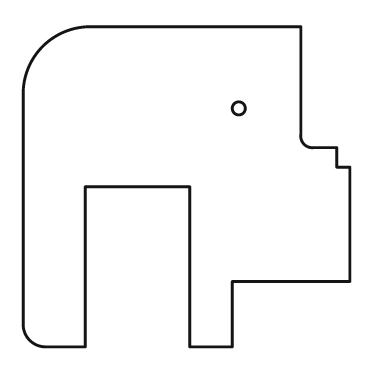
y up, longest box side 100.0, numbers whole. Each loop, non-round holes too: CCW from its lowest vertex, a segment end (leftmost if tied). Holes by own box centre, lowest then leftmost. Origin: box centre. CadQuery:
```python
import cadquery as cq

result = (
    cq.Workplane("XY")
    .moveTo(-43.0, -49.0)
    .lineTo(-31.0, -49.0)
    .lineTo(-31.0, 0.0)
    .lineTo(1.0, 0.0)
    .lineTo(1.0, -49.0)
    .lineTo(14.0, -49.0)
    .lineTo(14.0, -29.0)
    .lineTo(50.0, -29.0)
    .lineTo(50.0, 6.0)
    .lineTo(46.0, 6.0)
    .lineTo(46.0, 12.0)
    .lineTo(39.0, 12.0)
    .threePointArc((36.0, 13.0), (35.0, 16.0))
    .lineTo(35.0, 49.0)
    .lineTo(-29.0, 49.0)
    .threePointArc((-44.0, 43.0), (-50.0, 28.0))
    .lineTo(-50.0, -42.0)
    .threePointArc((-48.0, -47.0), (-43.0, -49.0))
    .close()
    .moveTo(16.0, 24.0)
    .circle(2.0)
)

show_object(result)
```